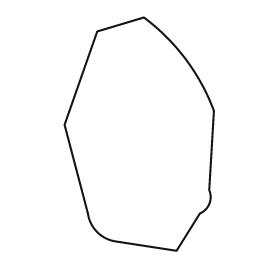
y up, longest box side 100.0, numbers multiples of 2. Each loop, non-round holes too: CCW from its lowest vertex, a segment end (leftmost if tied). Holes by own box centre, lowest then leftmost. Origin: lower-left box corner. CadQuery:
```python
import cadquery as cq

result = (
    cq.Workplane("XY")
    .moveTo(48.0, 0.0)
    .lineTo(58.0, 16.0)
    .threePointArc((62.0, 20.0), (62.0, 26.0))
    .lineTo(64.0, 60.0)
    .threePointArc((52.0, 82.0), (34.0, 100.0))
    .lineTo(14.0, 94.0)
    .lineTo(0.0, 54.0)
    .lineTo(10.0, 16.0)
    .threePointArc((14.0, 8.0), (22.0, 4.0))
    .close()
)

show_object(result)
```